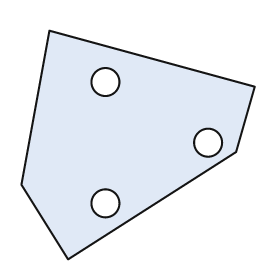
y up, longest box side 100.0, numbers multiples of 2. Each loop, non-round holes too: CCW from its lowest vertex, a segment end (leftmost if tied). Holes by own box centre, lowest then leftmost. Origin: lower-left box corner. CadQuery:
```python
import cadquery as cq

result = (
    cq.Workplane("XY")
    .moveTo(20.0, 0.0)
    .lineTo(92.0, 46.0)
    .lineTo(100.0, 74.0)
    .lineTo(12.0, 98.0)
    .lineTo(0.0, 32.0)
    .close()
    .moveTo(36.0, 24.0)
    .circle(6.0)
    .moveTo(80.0, 50.0)
    .circle(6.0)
    .moveTo(36.0, 76.0)
    .circle(6.0)
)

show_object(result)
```